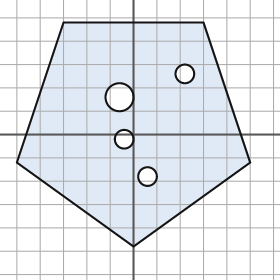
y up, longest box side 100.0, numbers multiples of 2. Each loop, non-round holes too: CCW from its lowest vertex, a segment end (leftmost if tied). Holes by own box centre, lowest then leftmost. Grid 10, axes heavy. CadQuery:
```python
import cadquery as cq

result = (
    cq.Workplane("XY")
    .moveTo(0.0, -48.0)
    .lineTo(50.0, -12.0)
    .lineTo(30.0, 48.0)
    .lineTo(-30.0, 48.0)
    .lineTo(-50.0, -12.0)
    .close()
    .moveTo(6.0, -18.0)
    .circle(4.0)
    .moveTo(-4.0, -2.0)
    .circle(4.0)
    .moveTo(-6.0, 16.0)
    .circle(6.0)
    .moveTo(22.0, 26.0)
    .circle(4.0)
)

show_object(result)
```